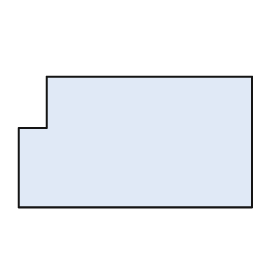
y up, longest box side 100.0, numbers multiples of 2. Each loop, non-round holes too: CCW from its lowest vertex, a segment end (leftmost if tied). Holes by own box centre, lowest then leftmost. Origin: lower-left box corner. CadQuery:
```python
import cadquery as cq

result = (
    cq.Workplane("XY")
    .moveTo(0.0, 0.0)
    .lineTo(100.0, 0.0)
    .lineTo(100.0, 56.0)
    .lineTo(12.0, 56.0)
    .lineTo(12.0, 34.0)
    .lineTo(0.0, 34.0)
    .close()
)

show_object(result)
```